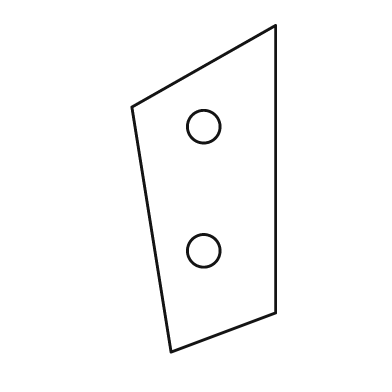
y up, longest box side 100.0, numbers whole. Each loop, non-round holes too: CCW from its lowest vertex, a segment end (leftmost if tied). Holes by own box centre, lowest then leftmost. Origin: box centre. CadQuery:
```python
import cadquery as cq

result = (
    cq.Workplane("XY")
    .moveTo(-10.0, -50.0)
    .lineTo(22.0, -38.0)
    .lineTo(22.0, 50.0)
    .lineTo(-22.0, 25.0)
    .close()
    .moveTo(0.0, -19.0)
    .circle(5.0)
    .moveTo(0.0, 19.0)
    .circle(5.0)
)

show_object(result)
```